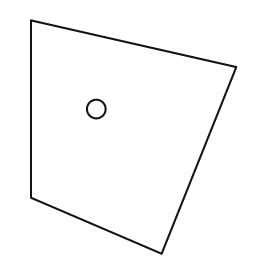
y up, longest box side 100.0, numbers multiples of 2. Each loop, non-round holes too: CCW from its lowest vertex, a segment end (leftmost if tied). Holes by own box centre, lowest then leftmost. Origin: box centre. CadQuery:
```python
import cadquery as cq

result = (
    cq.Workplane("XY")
    .moveTo(12.0, -50.0)
    .lineTo(44.0, 30.0)
    .lineTo(-44.0, 50.0)
    .lineTo(-44.0, -26.0)
    .close()
    .moveTo(-16.0, 12.0)
    .circle(4.0)
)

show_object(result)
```